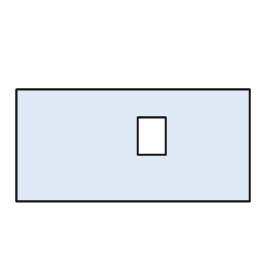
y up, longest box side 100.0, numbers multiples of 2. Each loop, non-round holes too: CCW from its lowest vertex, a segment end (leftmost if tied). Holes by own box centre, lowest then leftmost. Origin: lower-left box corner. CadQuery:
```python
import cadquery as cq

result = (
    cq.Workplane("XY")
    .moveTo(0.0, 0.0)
    .lineTo(100.0, 0.0)
    .lineTo(100.0, 48.0)
    .lineTo(0.0, 48.0)
    .close()
    .moveTo(52.0, 20.0)
    .lineTo(64.0, 20.0)
    .lineTo(64.0, 36.0)
    .lineTo(52.0, 36.0)
    .close()
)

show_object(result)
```